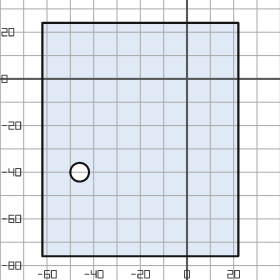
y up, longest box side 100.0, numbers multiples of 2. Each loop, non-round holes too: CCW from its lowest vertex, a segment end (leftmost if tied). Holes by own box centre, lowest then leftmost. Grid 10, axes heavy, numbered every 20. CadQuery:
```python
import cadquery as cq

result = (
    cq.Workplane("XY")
    .moveTo(-62.0, -76.0)
    .lineTo(22.0, -76.0)
    .lineTo(22.0, 24.0)
    .lineTo(-62.0, 24.0)
    .close()
    .moveTo(-46.0, -40.0)
    .circle(4.0)
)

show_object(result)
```